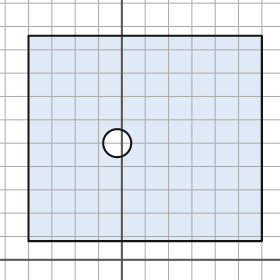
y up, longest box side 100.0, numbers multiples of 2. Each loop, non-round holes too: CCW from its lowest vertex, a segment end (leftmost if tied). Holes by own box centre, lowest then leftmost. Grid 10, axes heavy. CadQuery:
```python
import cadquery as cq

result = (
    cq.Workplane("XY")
    .moveTo(-40.0, 8.0)
    .lineTo(60.0, 8.0)
    .lineTo(60.0, 96.0)
    .lineTo(-40.0, 96.0)
    .close()
    .moveTo(-2.0, 50.0)
    .circle(6.0)
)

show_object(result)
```